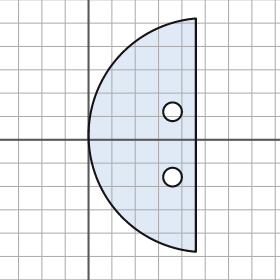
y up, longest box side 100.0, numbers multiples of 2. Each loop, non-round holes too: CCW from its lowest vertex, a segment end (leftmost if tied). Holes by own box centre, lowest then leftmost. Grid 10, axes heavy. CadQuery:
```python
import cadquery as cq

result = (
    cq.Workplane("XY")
    .moveTo(46.0, -48.0)
    .lineTo(46.0, 52.0)
    .threePointArc((0.0, 2.0), (46.0, -48.0))
    .close()
    .moveTo(36.0, -16.0)
    .circle(4.0)
    .moveTo(36.0, 12.0)
    .circle(4.0)
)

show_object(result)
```